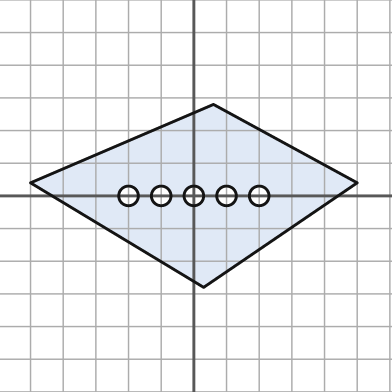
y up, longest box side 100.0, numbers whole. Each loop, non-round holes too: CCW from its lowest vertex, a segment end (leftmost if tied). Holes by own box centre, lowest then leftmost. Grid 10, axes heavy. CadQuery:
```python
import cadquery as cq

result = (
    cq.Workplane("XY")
    .moveTo(3.0, -28.0)
    .lineTo(50.0, 4.0)
    .lineTo(6.0, 28.0)
    .lineTo(-50.0, 4.0)
    .close()
    .moveTo(-20.0, 0.0)
    .circle(3.0)
    .moveTo(-10.0, 0.0)
    .circle(3.0)
    .moveTo(0.0, 0.0)
    .circle(3.0)
    .moveTo(10.0, 0.0)
    .circle(3.0)
    .moveTo(20.0, 0.0)
    .circle(3.0)
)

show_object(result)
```